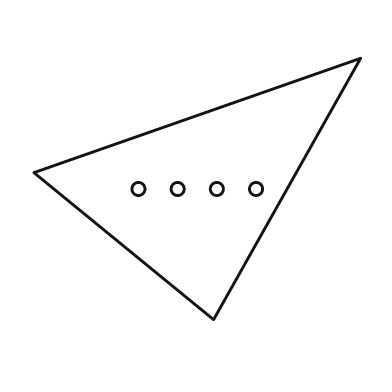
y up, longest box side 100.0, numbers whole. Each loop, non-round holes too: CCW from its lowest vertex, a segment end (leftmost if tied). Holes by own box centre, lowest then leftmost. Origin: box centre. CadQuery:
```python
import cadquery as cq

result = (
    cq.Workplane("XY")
    .moveTo(5.0, -40.0)
    .lineTo(50.0, 40.0)
    .lineTo(-50.0, 5.0)
    .close()
    .moveTo(-18.0, 0.0)
    .circle(2.0)
    .moveTo(-6.0, 0.0)
    .circle(2.0)
    .moveTo(6.0, 0.0)
    .circle(2.0)
    .moveTo(18.0, 0.0)
    .circle(2.0)
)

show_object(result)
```